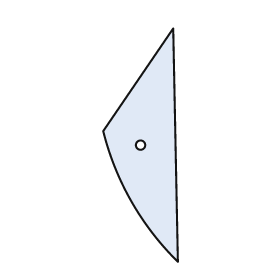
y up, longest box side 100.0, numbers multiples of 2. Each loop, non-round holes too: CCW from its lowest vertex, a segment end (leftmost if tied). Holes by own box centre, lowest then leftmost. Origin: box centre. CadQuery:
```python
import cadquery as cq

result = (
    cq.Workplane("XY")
    .moveTo(16.0, -50.0)
    .lineTo(14.0, 50.0)
    .lineTo(-16.0, 6.0)
    .threePointArc((-4.0, -24.0), (16.0, -50.0))
    .close()
    .moveTo(0.0, 0.0)
    .circle(2.0)
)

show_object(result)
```